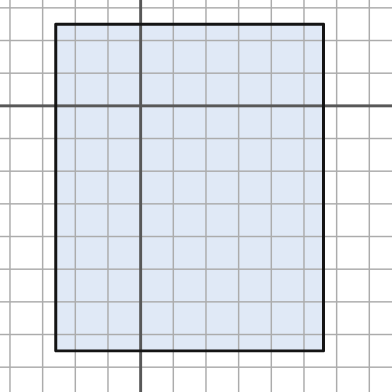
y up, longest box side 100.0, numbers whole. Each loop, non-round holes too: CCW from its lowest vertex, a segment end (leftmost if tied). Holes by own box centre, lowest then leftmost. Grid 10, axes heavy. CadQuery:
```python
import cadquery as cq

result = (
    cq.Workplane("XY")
    .moveTo(-26.0, -75.0)
    .lineTo(56.0, -75.0)
    .lineTo(56.0, 25.0)
    .lineTo(-26.0, 25.0)
    .close()
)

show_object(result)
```